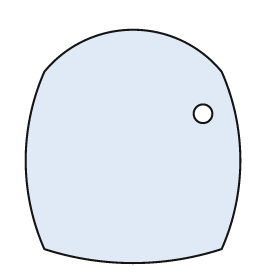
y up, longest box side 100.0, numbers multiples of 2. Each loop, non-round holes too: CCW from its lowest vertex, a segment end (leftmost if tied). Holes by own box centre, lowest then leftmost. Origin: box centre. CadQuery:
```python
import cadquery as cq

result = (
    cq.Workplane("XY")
    .moveTo(-38.0, -44.0)
    .threePointArc((0.0, -50.0), (38.0, -44.0))
    .threePointArc((46.0, -6.0), (38.0, 32.0))
    .threePointArc((0.0, 50.0), (-38.0, 32.0))
    .threePointArc((-46.0, -6.0), (-38.0, -44.0))
    .close()
    .moveTo(30.0, 14.0)
    .circle(4.0)
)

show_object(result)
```